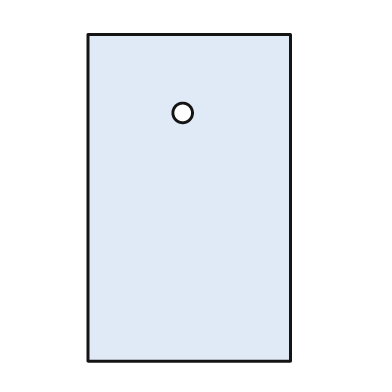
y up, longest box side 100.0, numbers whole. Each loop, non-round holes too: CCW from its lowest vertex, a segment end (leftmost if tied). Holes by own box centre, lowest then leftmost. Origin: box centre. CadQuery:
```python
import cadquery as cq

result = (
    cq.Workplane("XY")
    .moveTo(-31.0, -50.0)
    .lineTo(31.0, -50.0)
    .lineTo(31.0, 50.0)
    .lineTo(-31.0, 50.0)
    .close()
    .moveTo(-2.0, 26.0)
    .circle(3.0)
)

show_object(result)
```